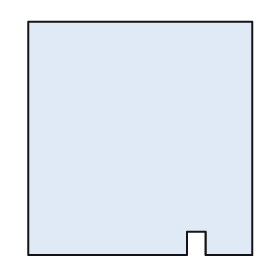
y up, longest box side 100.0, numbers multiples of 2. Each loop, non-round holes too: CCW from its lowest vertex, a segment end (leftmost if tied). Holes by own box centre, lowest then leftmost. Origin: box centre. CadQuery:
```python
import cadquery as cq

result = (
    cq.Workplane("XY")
    .moveTo(-48.0, -50.0)
    .lineTo(20.0, -50.0)
    .lineTo(20.0, -40.0)
    .lineTo(28.0, -40.0)
    .lineTo(28.0, -50.0)
    .lineTo(48.0, -50.0)
    .lineTo(48.0, 50.0)
    .lineTo(-48.0, 50.0)
    .close()
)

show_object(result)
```